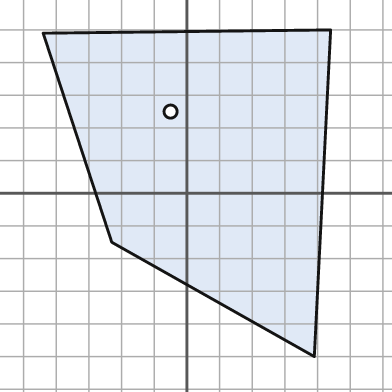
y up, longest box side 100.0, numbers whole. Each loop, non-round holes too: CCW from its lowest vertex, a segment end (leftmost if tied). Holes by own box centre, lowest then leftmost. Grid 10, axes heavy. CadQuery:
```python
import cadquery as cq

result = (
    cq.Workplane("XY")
    .moveTo(39.0, -50.0)
    .lineTo(44.0, 50.0)
    .lineTo(-44.0, 49.0)
    .lineTo(-23.0, -15.0)
    .close()
    .moveTo(-5.0, 25.0)
    .circle(2.0)
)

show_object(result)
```